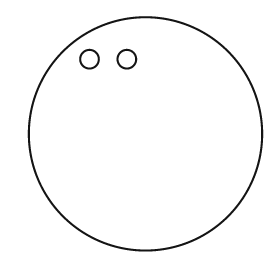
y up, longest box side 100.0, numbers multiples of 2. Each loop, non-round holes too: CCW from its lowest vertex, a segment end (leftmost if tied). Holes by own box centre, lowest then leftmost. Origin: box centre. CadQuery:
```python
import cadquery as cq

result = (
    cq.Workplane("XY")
    .moveTo(0.0, 0.0)
    .circle(50.0)
    .moveTo(-24.0, 32.0)
    .circle(4.0)
    .moveTo(-8.0, 32.0)
    .circle(4.0)
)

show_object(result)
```